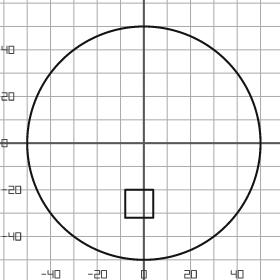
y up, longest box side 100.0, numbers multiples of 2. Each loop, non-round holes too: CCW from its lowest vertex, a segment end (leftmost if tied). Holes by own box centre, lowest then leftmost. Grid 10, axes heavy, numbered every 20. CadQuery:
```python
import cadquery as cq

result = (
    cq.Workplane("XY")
    .moveTo(0.0, 0.0)
    .circle(50.0)
    .moveTo(-8.0, -32.0)
    .lineTo(4.0, -32.0)
    .lineTo(4.0, -20.0)
    .lineTo(-8.0, -20.0)
    .close()
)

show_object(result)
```